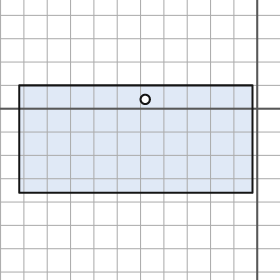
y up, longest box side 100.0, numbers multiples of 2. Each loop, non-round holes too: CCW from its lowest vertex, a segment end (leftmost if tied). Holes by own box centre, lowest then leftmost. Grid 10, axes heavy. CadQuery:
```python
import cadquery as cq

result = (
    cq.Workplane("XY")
    .moveTo(-102.0, -36.0)
    .lineTo(-2.0, -36.0)
    .lineTo(-2.0, 10.0)
    .lineTo(-102.0, 10.0)
    .close()
    .moveTo(-48.0, 4.0)
    .circle(2.0)
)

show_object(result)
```